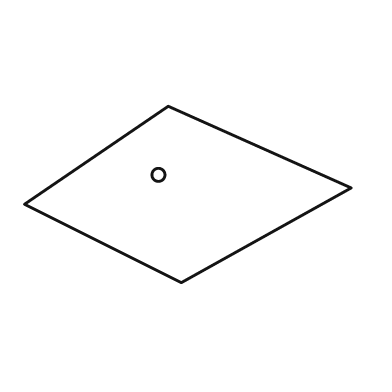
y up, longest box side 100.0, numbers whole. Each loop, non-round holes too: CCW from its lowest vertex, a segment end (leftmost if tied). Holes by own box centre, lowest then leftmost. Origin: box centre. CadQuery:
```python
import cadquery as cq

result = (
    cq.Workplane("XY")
    .moveTo(-2.0, -27.0)
    .lineTo(50.0, 2.0)
    .lineTo(-6.0, 27.0)
    .lineTo(-50.0, -3.0)
    .close()
    .moveTo(-9.0, 6.0)
    .circle(2.0)
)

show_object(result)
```